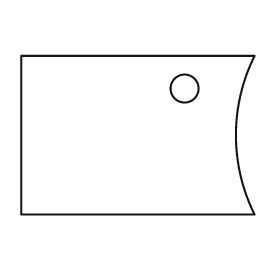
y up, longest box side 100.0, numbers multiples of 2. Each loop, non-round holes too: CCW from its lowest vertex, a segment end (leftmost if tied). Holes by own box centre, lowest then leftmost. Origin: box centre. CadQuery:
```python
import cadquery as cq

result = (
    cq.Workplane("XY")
    .moveTo(-50.0, -34.0)
    .lineTo(50.0, -34.0)
    .threePointArc((42.0, 0.0), (50.0, 34.0))
    .lineTo(-50.0, 34.0)
    .close()
    .moveTo(20.0, 20.0)
    .circle(6.0)
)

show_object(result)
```